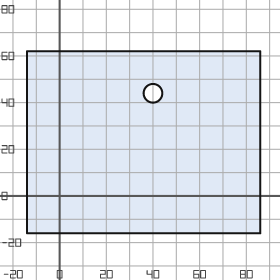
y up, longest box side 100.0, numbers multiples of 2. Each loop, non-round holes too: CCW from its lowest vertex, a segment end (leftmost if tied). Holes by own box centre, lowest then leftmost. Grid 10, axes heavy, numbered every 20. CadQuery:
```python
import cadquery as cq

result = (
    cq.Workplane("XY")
    .moveTo(-14.0, -16.0)
    .lineTo(86.0, -16.0)
    .lineTo(86.0, 62.0)
    .lineTo(-14.0, 62.0)
    .close()
    .moveTo(40.0, 44.0)
    .circle(4.0)
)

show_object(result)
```